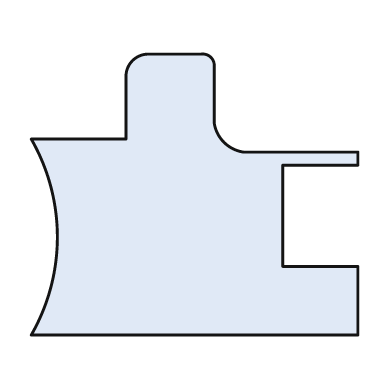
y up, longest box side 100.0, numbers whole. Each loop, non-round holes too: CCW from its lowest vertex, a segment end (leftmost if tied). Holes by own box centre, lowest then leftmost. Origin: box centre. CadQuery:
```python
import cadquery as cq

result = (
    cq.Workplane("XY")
    .moveTo(-50.0, -43.0)
    .lineTo(50.0, -43.0)
    .lineTo(50.0, -22.0)
    .lineTo(27.0, -22.0)
    .lineTo(27.0, 9.0)
    .lineTo(50.0, 9.0)
    .lineTo(50.0, 13.0)
    .lineTo(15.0, 13.0)
    .threePointArc((9.0, 16.0), (6.0, 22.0))
    .lineTo(6.0, 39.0)
    .threePointArc((5.0, 42.0), (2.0, 43.0))
    .lineTo(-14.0, 43.0)
    .threePointArc((-19.0, 41.0), (-21.0, 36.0))
    .lineTo(-21.0, 17.0)
    .lineTo(-50.0, 17.0)
    .threePointArc((-42.0, -13.0), (-50.0, -43.0))
    .close()
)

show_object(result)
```